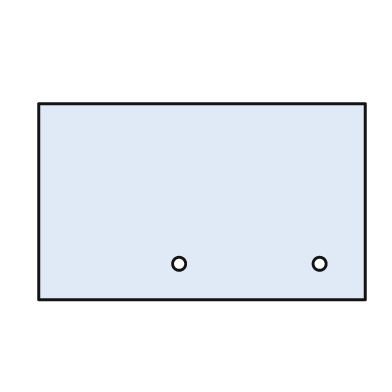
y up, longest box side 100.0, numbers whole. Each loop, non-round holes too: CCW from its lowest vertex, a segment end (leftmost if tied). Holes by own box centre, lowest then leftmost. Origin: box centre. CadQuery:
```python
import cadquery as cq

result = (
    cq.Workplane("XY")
    .moveTo(-50.0, -30.0)
    .lineTo(50.0, -30.0)
    .lineTo(50.0, 30.0)
    .lineTo(-50.0, 30.0)
    .close()
    .moveTo(-7.0, -19.0)
    .circle(2.0)
    .moveTo(36.0, -19.0)
    .circle(2.0)
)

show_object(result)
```